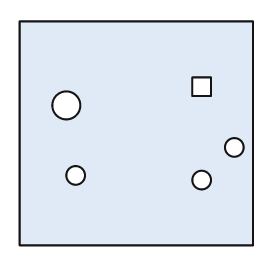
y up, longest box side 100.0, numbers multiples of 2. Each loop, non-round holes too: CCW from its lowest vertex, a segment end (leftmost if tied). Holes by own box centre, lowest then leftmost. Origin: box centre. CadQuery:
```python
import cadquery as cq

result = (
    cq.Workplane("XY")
    .moveTo(-50.0, -48.0)
    .lineTo(50.0, -48.0)
    .lineTo(50.0, 48.0)
    .lineTo(-50.0, 48.0)
    .close()
    .moveTo(28.0, -20.0)
    .circle(4.0)
    .moveTo(-26.0, -18.0)
    .circle(4.0)
    .moveTo(42.0, -6.0)
    .circle(4.0)
    .moveTo(-30.0, 12.0)
    .circle(6.0)
    .moveTo(24.0, 16.0)
    .lineTo(32.0, 16.0)
    .lineTo(32.0, 24.0)
    .lineTo(24.0, 24.0)
    .close()
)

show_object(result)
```